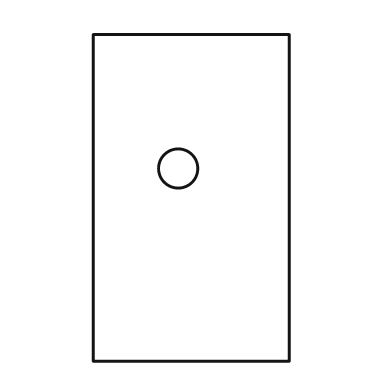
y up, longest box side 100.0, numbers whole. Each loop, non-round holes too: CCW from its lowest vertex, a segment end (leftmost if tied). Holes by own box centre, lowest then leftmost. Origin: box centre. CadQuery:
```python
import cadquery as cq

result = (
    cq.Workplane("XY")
    .moveTo(-30.0, -50.0)
    .lineTo(30.0, -50.0)
    .lineTo(30.0, 50.0)
    .lineTo(-30.0, 50.0)
    .close()
    .moveTo(-4.0, 9.0)
    .circle(6.0)
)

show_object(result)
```